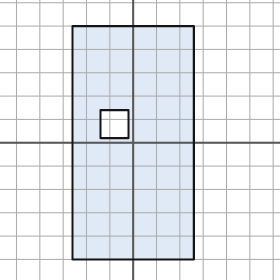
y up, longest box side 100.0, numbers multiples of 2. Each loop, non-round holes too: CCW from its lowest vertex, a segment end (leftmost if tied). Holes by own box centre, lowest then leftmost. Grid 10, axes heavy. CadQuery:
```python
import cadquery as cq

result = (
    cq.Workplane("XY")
    .moveTo(-26.0, -50.0)
    .lineTo(26.0, -50.0)
    .lineTo(26.0, 50.0)
    .lineTo(-26.0, 50.0)
    .close()
    .moveTo(-14.0, 2.0)
    .lineTo(-2.0, 2.0)
    .lineTo(-2.0, 14.0)
    .lineTo(-14.0, 14.0)
    .close()
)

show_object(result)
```